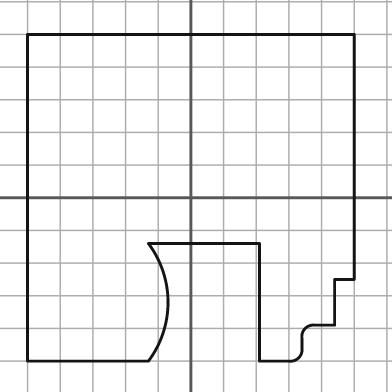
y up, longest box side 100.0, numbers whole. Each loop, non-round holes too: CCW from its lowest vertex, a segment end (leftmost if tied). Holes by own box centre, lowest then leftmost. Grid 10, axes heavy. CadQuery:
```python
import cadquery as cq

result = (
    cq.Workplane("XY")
    .moveTo(-50.0, -50.0)
    .lineTo(-13.0, -50.0)
    .threePointArc((-7.0, -32.0), (-13.0, -14.0))
    .lineTo(21.0, -14.0)
    .lineTo(21.0, -50.0)
    .lineTo(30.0, -50.0)
    .threePointArc((33.0, -49.0), (34.0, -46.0))
    .lineTo(34.0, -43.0)
    .threePointArc((35.0, -40.0), (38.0, -39.0))
    .lineTo(44.0, -39.0)
    .lineTo(44.0, -25.0)
    .lineTo(50.0, -25.0)
    .lineTo(50.0, 50.0)
    .lineTo(-50.0, 50.0)
    .close()
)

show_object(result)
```